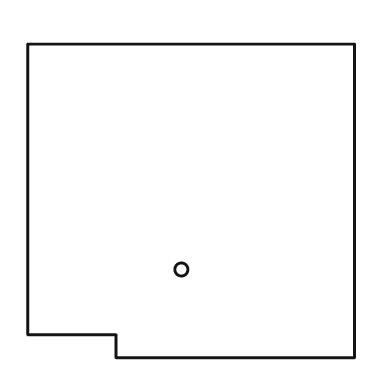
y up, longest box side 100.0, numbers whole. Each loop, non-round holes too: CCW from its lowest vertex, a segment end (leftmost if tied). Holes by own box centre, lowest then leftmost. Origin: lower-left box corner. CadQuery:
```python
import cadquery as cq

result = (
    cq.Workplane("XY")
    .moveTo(27.0, 0.0)
    .lineTo(100.0, 0.0)
    .lineTo(100.0, 96.0)
    .lineTo(0.0, 96.0)
    .lineTo(0.0, 7.0)
    .lineTo(27.0, 7.0)
    .close()
    .moveTo(47.0, 27.0)
    .circle(2.0)
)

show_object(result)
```